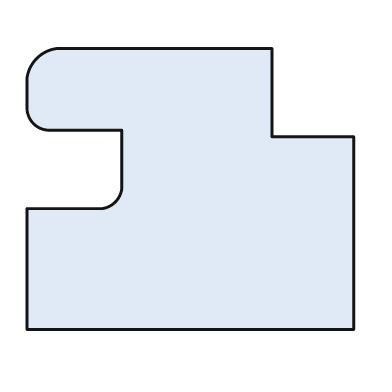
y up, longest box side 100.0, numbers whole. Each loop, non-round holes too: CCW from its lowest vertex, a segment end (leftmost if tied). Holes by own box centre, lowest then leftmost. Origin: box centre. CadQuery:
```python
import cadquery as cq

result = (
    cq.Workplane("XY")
    .moveTo(-50.0, -43.0)
    .lineTo(50.0, -43.0)
    .lineTo(50.0, 16.0)
    .lineTo(25.0, 16.0)
    .lineTo(25.0, 43.0)
    .lineTo(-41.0, 43.0)
    .threePointArc((-47.0, 40.0), (-50.0, 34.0))
    .lineTo(-50.0, 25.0)
    .threePointArc((-48.0, 20.0), (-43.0, 18.0))
    .lineTo(-21.0, 18.0)
    .lineTo(-21.0, 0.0)
    .threePointArc((-23.0, -4.0), (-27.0, -6.0))
    .lineTo(-50.0, -6.0)
    .close()
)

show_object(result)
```